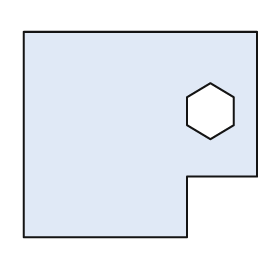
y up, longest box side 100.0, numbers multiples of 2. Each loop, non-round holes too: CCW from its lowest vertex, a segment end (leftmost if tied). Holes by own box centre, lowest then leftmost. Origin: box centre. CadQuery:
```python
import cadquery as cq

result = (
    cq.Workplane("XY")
    .moveTo(-50.0, -44.0)
    .lineTo(20.0, -44.0)
    .lineTo(20.0, -18.0)
    .lineTo(50.0, -18.0)
    .lineTo(50.0, 44.0)
    .lineTo(-50.0, 44.0)
    .close()
    .moveTo(30.0, -2.0)
    .lineTo(40.0, 4.0)
    .lineTo(40.0, 16.0)
    .lineTo(30.0, 22.0)
    .lineTo(20.0, 16.0)
    .lineTo(20.0, 4.0)
    .close()
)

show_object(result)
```